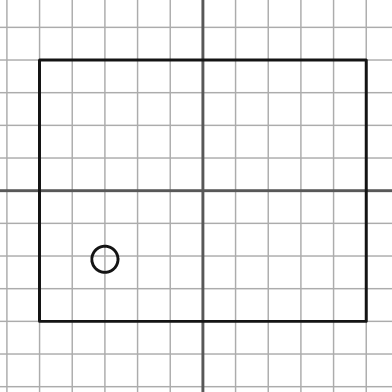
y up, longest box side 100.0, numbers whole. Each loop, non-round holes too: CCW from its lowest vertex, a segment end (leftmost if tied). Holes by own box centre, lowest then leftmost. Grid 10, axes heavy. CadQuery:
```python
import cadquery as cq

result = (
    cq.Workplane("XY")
    .moveTo(-50.0, -40.0)
    .lineTo(50.0, -40.0)
    .lineTo(50.0, 40.0)
    .lineTo(-50.0, 40.0)
    .close()
    .moveTo(-30.0, -21.0)
    .circle(4.0)
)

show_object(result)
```